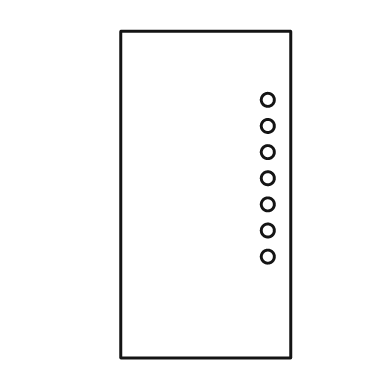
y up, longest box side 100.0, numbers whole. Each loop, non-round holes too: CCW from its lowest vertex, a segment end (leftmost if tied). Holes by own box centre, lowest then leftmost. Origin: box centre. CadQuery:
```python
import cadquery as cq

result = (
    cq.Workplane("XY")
    .moveTo(-26.0, -50.0)
    .lineTo(26.0, -50.0)
    .lineTo(26.0, 50.0)
    .lineTo(-26.0, 50.0)
    .close()
    .moveTo(19.0, -19.0)
    .circle(2.0)
    .moveTo(19.0, -11.0)
    .circle(2.0)
    .moveTo(19.0, -3.0)
    .circle(2.0)
    .moveTo(19.0, 5.0)
    .circle(2.0)
    .moveTo(19.0, 13.0)
    .circle(2.0)
    .moveTo(19.0, 21.0)
    .circle(2.0)
    .moveTo(19.0, 29.0)
    .circle(2.0)
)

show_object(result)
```